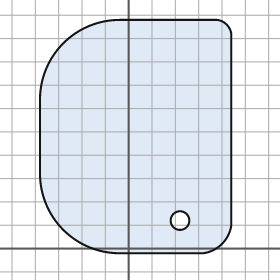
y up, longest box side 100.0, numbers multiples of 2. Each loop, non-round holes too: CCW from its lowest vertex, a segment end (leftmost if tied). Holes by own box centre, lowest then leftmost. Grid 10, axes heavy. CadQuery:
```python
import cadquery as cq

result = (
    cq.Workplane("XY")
    .moveTo(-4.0, -2.0)
    .lineTo(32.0, -2.0)
    .threePointArc((40.0, 2.0), (44.0, 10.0))
    .lineTo(44.0, 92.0)
    .threePointArc((42.0, 96.0), (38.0, 98.0))
    .lineTo(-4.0, 98.0)
    .threePointArc((-28.0, 88.0), (-38.0, 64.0))
    .lineTo(-38.0, 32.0)
    .threePointArc((-28.0, 8.0), (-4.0, -2.0))
    .close()
    .moveTo(22.0, 12.0)
    .circle(4.0)
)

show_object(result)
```